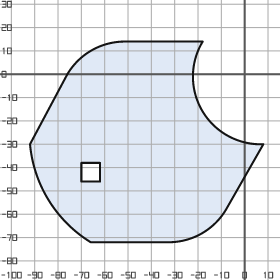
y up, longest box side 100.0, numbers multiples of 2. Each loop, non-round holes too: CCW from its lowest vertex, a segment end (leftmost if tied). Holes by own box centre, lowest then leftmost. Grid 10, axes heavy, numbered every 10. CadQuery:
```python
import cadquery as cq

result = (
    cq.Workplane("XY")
    .moveTo(-66.0, -72.0)
    .lineTo(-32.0, -72.0)
    .threePointArc((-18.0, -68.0), (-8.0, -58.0))
    .lineTo(8.0, -30.0)
    .threePointArc((-18.0, -16.0), (-18.0, 14.0))
    .lineTo(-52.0, 14.0)
    .threePointArc((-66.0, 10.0), (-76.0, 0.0))
    .lineTo(-92.0, -30.0)
    .threePointArc((-84.0, -54.0), (-66.0, -72.0))
    .close()
    .moveTo(-70.0, -46.0)
    .lineTo(-62.0, -46.0)
    .lineTo(-62.0, -38.0)
    .lineTo(-70.0, -38.0)
    .close()
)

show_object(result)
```